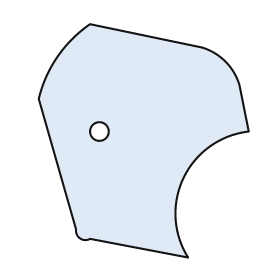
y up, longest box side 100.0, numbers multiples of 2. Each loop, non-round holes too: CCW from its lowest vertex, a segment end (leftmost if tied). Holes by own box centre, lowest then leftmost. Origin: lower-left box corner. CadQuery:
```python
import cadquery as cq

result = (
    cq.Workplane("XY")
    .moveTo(64.0, 0.0)
    .threePointArc((62.0, 34.0), (90.0, 54.0))
    .lineTo(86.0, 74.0)
    .threePointArc((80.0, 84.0), (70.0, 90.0))
    .lineTo(22.0, 100.0)
    .threePointArc((8.0, 86.0), (0.0, 68.0))
    .lineTo(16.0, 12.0)
    .threePointArc((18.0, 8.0), (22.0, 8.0))
    .close()
    .moveTo(26.0, 54.0)
    .circle(4.0)
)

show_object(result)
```